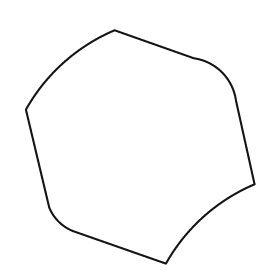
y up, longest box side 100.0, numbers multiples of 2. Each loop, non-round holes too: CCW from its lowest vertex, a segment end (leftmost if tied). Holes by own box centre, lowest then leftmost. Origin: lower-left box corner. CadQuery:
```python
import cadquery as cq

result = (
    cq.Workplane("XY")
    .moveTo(60.0, 0.0)
    .threePointArc((76.0, 20.0), (98.0, 34.0))
    .lineTo(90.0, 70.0)
    .threePointArc((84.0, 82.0), (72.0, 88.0))
    .lineTo(38.0, 100.0)
    .threePointArc((16.0, 86.0), (0.0, 66.0))
    .lineTo(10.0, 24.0)
    .threePointArc((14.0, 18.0), (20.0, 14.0))
    .close()
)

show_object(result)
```